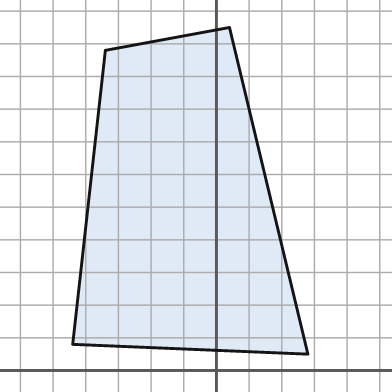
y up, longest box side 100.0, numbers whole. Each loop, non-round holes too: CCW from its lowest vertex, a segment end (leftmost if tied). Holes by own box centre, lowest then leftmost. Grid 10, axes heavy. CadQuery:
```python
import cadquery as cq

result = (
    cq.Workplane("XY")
    .moveTo(28.0, 5.0)
    .lineTo(4.0, 105.0)
    .lineTo(-34.0, 98.0)
    .lineTo(-44.0, 8.0)
    .close()
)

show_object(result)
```